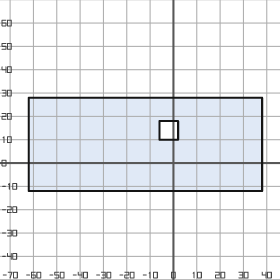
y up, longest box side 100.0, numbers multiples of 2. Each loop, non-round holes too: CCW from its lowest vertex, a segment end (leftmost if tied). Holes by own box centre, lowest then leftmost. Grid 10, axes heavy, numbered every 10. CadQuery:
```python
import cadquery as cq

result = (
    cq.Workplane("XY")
    .moveTo(-62.0, -12.0)
    .lineTo(38.0, -12.0)
    .lineTo(38.0, 28.0)
    .lineTo(-62.0, 28.0)
    .close()
    .moveTo(-6.0, 10.0)
    .lineTo(2.0, 10.0)
    .lineTo(2.0, 18.0)
    .lineTo(-6.0, 18.0)
    .close()
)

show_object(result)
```